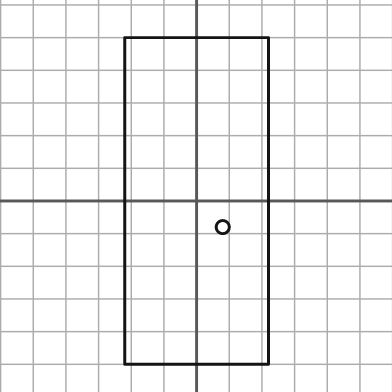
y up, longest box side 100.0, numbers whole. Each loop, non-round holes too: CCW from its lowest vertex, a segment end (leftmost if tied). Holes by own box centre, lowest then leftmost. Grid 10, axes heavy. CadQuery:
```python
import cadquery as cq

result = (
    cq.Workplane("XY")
    .moveTo(-22.0, -50.0)
    .lineTo(22.0, -50.0)
    .lineTo(22.0, 50.0)
    .lineTo(-22.0, 50.0)
    .close()
    .moveTo(8.0, -8.0)
    .circle(2.0)
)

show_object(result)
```